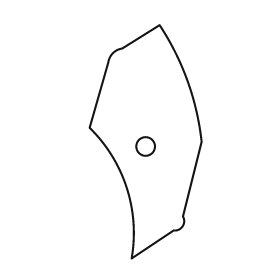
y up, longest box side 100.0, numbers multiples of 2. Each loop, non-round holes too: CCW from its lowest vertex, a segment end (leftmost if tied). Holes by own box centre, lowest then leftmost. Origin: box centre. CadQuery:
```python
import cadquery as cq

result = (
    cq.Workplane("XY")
    .moveTo(-6.0, -50.0)
    .lineTo(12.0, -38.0)
    .threePointArc((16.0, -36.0), (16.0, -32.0))
    .lineTo(24.0, 0.0)
    .threePointArc((18.0, 26.0), (6.0, 50.0))
    .lineTo(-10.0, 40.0)
    .threePointArc((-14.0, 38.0), (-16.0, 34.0))
    .lineTo(-24.0, 6.0)
    .threePointArc((-8.0, -20.0), (-6.0, -50.0))
    .close()
    .moveTo(0.0, -2.0)
    .circle(4.0)
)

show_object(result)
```